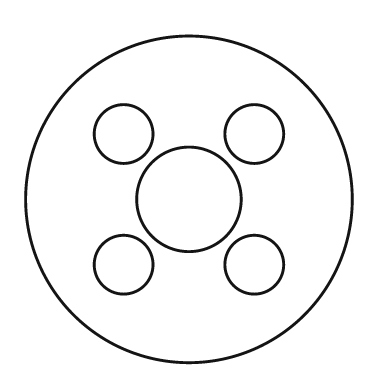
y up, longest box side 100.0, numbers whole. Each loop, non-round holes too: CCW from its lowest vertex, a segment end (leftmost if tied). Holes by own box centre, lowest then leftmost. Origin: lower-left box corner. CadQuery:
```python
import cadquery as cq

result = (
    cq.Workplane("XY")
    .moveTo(50.0, 50.0)
    .circle(50.0)
    .moveTo(30.0, 30.0)
    .circle(9.0)
    .moveTo(70.0, 30.0)
    .circle(9.0)
    .moveTo(50.0, 50.0)
    .circle(16.0)
    .moveTo(30.0, 70.0)
    .circle(9.0)
    .moveTo(70.0, 70.0)
    .circle(9.0)
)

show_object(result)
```